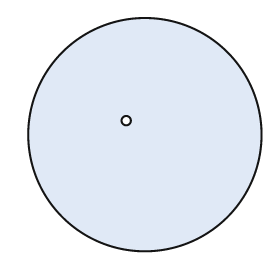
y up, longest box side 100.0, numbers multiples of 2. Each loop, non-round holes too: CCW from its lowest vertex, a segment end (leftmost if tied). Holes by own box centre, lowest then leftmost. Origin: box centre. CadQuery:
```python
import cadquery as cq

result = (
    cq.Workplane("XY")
    .moveTo(0.0, 0.0)
    .circle(50.0)
    .moveTo(-8.0, 6.0)
    .circle(2.0)
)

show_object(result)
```